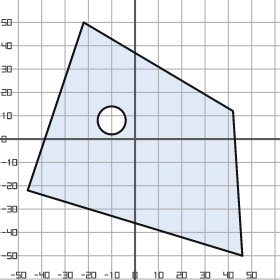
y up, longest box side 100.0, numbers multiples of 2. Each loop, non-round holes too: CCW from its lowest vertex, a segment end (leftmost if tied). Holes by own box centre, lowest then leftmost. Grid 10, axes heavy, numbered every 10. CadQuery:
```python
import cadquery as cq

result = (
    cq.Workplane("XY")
    .moveTo(46.0, -50.0)
    .lineTo(42.0, 12.0)
    .lineTo(-22.0, 50.0)
    .lineTo(-46.0, -22.0)
    .close()
    .moveTo(-10.0, 8.0)
    .circle(6.0)
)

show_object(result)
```